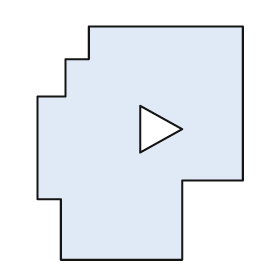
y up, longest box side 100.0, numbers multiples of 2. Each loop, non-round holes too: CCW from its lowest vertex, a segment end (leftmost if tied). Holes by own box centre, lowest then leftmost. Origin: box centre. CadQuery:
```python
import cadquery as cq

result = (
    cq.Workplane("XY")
    .moveTo(-34.0, -50.0)
    .lineTo(18.0, -50.0)
    .lineTo(18.0, -16.0)
    .lineTo(44.0, -16.0)
    .lineTo(44.0, 50.0)
    .lineTo(-22.0, 50.0)
    .lineTo(-22.0, 36.0)
    .lineTo(-32.0, 36.0)
    .lineTo(-32.0, 20.0)
    .lineTo(-44.0, 20.0)
    .lineTo(-44.0, -24.0)
    .lineTo(-34.0, -24.0)
    .close()
    .moveTo(0.0, -4.0)
    .lineTo(18.0, 6.0)
    .lineTo(0.0, 16.0)
    .close()
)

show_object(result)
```